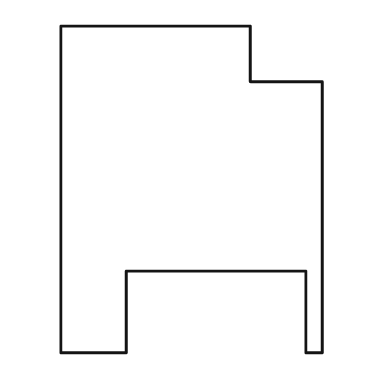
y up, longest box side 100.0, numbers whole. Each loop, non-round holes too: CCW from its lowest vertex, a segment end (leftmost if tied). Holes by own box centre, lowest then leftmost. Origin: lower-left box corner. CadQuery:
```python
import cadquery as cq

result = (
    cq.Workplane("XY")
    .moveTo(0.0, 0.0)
    .lineTo(20.0, 0.0)
    .lineTo(20.0, 25.0)
    .lineTo(75.0, 25.0)
    .lineTo(75.0, 0.0)
    .lineTo(80.0, 0.0)
    .lineTo(80.0, 83.0)
    .lineTo(58.0, 83.0)
    .lineTo(58.0, 100.0)
    .lineTo(0.0, 100.0)
    .close()
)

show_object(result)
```